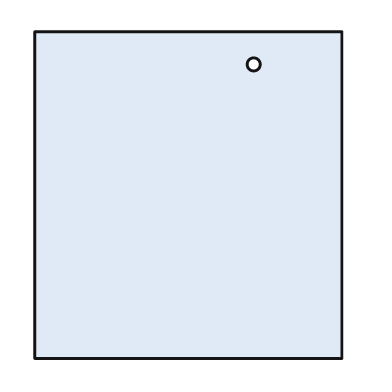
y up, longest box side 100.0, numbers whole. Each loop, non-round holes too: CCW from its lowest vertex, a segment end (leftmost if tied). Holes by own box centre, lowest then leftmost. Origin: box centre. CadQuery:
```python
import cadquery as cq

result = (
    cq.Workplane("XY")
    .moveTo(-47.0, -50.0)
    .lineTo(47.0, -50.0)
    .lineTo(47.0, 50.0)
    .lineTo(-47.0, 50.0)
    .close()
    .moveTo(20.0, 40.0)
    .circle(2.0)
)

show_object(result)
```